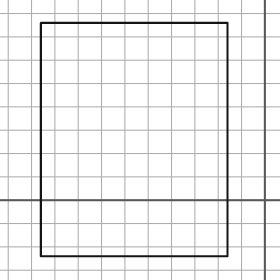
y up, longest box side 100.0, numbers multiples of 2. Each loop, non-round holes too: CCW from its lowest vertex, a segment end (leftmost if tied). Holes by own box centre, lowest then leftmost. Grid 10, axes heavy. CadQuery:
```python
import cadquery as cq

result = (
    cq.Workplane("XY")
    .moveTo(-96.0, -24.0)
    .lineTo(-16.0, -24.0)
    .lineTo(-16.0, 76.0)
    .lineTo(-96.0, 76.0)
    .close()
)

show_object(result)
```